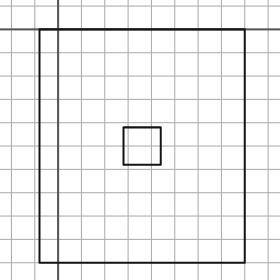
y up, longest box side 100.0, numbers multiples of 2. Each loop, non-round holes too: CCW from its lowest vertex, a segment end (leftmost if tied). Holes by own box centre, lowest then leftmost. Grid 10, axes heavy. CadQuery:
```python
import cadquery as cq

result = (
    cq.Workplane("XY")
    .moveTo(-8.0, -100.0)
    .lineTo(80.0, -100.0)
    .lineTo(80.0, 0.0)
    .lineTo(-8.0, 0.0)
    .close()
    .moveTo(28.0, -58.0)
    .lineTo(44.0, -58.0)
    .lineTo(44.0, -42.0)
    .lineTo(28.0, -42.0)
    .close()
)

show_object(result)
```